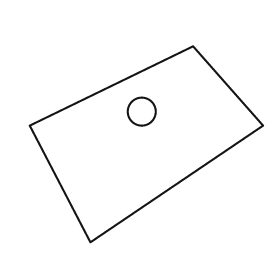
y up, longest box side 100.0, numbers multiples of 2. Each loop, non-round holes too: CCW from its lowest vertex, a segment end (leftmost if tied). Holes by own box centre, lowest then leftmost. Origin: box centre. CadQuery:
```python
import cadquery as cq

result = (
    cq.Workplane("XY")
    .moveTo(-24.0, -42.0)
    .lineTo(50.0, 8.0)
    .lineTo(20.0, 42.0)
    .lineTo(-50.0, 8.0)
    .close()
    .moveTo(-2.0, 14.0)
    .circle(6.0)
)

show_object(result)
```